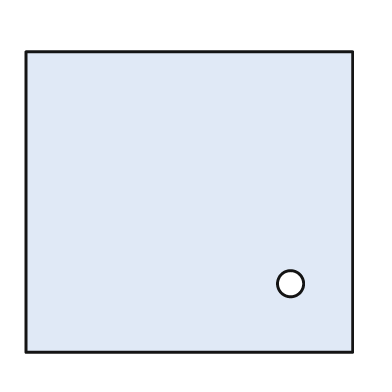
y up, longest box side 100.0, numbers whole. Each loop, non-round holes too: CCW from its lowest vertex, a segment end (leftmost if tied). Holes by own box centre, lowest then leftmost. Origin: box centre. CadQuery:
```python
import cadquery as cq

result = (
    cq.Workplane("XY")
    .moveTo(-50.0, -46.0)
    .lineTo(50.0, -46.0)
    .lineTo(50.0, 46.0)
    .lineTo(-50.0, 46.0)
    .close()
    .moveTo(31.0, -25.0)
    .circle(4.0)
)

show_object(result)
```